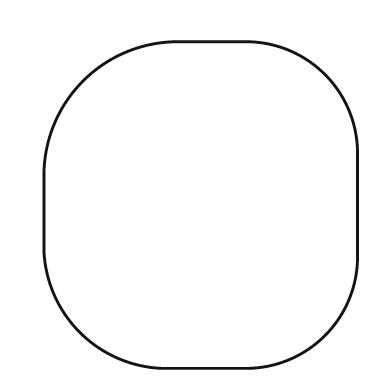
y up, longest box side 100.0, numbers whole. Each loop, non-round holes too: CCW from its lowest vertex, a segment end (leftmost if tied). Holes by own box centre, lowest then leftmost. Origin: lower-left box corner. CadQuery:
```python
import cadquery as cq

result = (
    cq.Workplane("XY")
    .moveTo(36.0, 0.0)
    .lineTo(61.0, 0.0)
    .threePointArc((86.0, 10.0), (96.0, 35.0))
    .lineTo(96.0, 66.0)
    .threePointArc((86.0, 90.0), (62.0, 100.0))
    .lineTo(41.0, 100.0)
    .threePointArc((12.0, 88.0), (0.0, 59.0))
    .lineTo(0.0, 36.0)
    .threePointArc((11.0, 11.0), (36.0, 0.0))
    .close()
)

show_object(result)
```